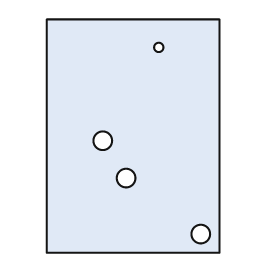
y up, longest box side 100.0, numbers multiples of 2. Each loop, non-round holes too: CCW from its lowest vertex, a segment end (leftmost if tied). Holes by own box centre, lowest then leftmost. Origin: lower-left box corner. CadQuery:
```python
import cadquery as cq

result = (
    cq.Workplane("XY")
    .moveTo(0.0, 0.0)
    .lineTo(74.0, 0.0)
    .lineTo(74.0, 100.0)
    .lineTo(0.0, 100.0)
    .close()
    .moveTo(66.0, 8.0)
    .circle(4.0)
    .moveTo(34.0, 32.0)
    .circle(4.0)
    .moveTo(24.0, 48.0)
    .circle(4.0)
    .moveTo(48.0, 88.0)
    .circle(2.0)
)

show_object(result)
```